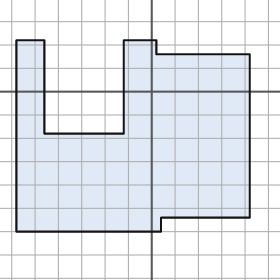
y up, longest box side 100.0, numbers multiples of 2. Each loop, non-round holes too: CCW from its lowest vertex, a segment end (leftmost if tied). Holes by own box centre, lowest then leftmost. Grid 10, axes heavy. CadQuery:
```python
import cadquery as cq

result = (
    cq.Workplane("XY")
    .moveTo(-58.0, -60.0)
    .lineTo(4.0, -60.0)
    .lineTo(4.0, -54.0)
    .lineTo(42.0, -54.0)
    .lineTo(42.0, 16.0)
    .lineTo(2.0, 16.0)
    .lineTo(2.0, 22.0)
    .lineTo(-12.0, 22.0)
    .lineTo(-12.0, -18.0)
    .lineTo(-46.0, -18.0)
    .lineTo(-46.0, 22.0)
    .lineTo(-58.0, 22.0)
    .close()
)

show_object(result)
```